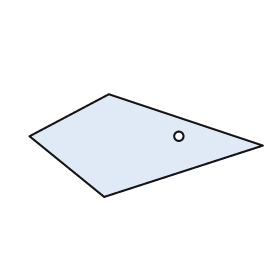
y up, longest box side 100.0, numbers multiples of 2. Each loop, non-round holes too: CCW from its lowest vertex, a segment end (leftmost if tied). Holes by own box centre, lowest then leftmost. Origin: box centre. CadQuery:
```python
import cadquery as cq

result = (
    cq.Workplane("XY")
    .moveTo(-18.0, -22.0)
    .lineTo(50.0, 0.0)
    .lineTo(-16.0, 22.0)
    .lineTo(-50.0, 4.0)
    .close()
    .moveTo(14.0, 4.0)
    .circle(2.0)
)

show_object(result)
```